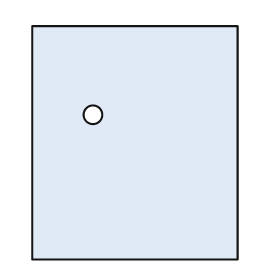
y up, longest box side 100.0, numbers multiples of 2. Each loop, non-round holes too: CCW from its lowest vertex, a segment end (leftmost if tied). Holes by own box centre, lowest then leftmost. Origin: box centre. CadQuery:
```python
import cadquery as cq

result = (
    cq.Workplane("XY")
    .moveTo(-44.0, -50.0)
    .lineTo(44.0, -50.0)
    .lineTo(44.0, 50.0)
    .lineTo(-44.0, 50.0)
    .close()
    .moveTo(-18.0, 12.0)
    .circle(4.0)
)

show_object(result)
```